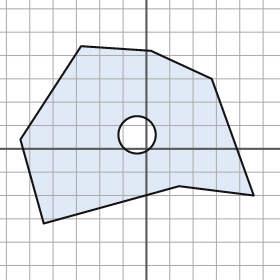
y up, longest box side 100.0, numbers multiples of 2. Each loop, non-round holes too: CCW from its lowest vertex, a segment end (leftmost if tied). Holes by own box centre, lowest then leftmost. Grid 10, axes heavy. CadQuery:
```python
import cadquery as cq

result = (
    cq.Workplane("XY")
    .moveTo(-44.0, -32.0)
    .lineTo(14.0, -16.0)
    .lineTo(46.0, -20.0)
    .lineTo(28.0, 30.0)
    .lineTo(2.0, 42.0)
    .lineTo(-28.0, 44.0)
    .lineTo(-54.0, 4.0)
    .close()
    .moveTo(-4.0, 6.0)
    .circle(8.0)
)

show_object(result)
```